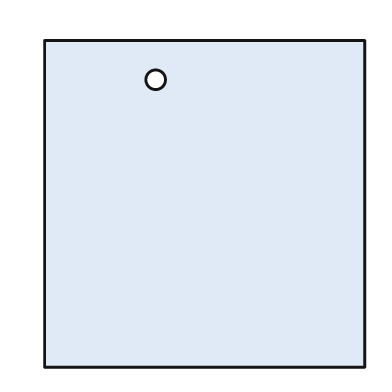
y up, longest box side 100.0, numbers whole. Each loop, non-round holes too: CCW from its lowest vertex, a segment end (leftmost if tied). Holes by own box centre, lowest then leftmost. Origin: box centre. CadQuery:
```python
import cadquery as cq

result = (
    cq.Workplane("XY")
    .moveTo(-49.0, -50.0)
    .lineTo(49.0, -50.0)
    .lineTo(49.0, 50.0)
    .lineTo(-49.0, 50.0)
    .close()
    .moveTo(-15.0, 38.0)
    .circle(3.0)
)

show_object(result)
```